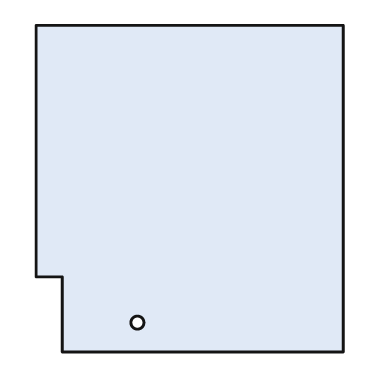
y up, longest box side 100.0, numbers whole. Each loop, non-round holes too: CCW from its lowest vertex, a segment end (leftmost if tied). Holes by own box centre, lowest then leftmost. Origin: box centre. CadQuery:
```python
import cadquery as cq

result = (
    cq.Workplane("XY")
    .moveTo(-39.0, -50.0)
    .lineTo(47.0, -50.0)
    .lineTo(47.0, 50.0)
    .lineTo(-47.0, 50.0)
    .lineTo(-47.0, -27.0)
    .lineTo(-39.0, -27.0)
    .close()
    .moveTo(-16.0, -41.0)
    .circle(2.0)
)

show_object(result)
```